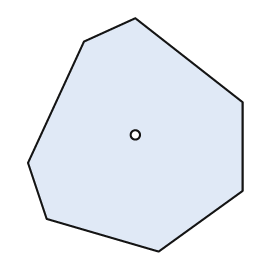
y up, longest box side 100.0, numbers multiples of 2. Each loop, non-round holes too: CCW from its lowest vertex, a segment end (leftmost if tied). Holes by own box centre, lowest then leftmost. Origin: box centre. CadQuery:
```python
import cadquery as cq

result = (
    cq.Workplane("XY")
    .moveTo(10.0, -50.0)
    .lineTo(46.0, -24.0)
    .lineTo(46.0, 14.0)
    .lineTo(0.0, 50.0)
    .lineTo(-22.0, 40.0)
    .lineTo(-46.0, -12.0)
    .lineTo(-38.0, -36.0)
    .close()
    .moveTo(0.0, 0.0)
    .circle(2.0)
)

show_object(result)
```